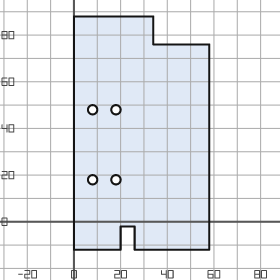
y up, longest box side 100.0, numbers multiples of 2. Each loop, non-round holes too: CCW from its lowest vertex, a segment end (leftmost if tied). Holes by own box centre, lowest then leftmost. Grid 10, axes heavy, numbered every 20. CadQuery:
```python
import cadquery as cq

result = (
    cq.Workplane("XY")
    .moveTo(0.0, -12.0)
    .lineTo(20.0, -12.0)
    .lineTo(20.0, -2.0)
    .lineTo(26.0, -2.0)
    .lineTo(26.0, -12.0)
    .lineTo(58.0, -12.0)
    .lineTo(58.0, 76.0)
    .lineTo(34.0, 76.0)
    .lineTo(34.0, 88.0)
    .lineTo(0.0, 88.0)
    .close()
    .moveTo(8.0, 18.0)
    .circle(2.0)
    .moveTo(18.0, 18.0)
    .circle(2.0)
    .moveTo(8.0, 48.0)
    .circle(2.0)
    .moveTo(18.0, 48.0)
    .circle(2.0)
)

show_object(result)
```